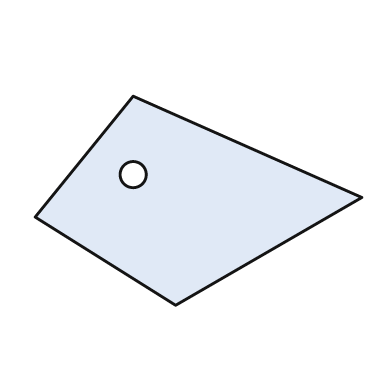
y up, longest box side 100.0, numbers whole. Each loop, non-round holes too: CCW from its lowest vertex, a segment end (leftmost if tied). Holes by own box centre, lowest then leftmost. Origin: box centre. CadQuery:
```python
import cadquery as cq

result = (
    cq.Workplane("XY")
    .moveTo(-7.0, -32.0)
    .lineTo(50.0, 1.0)
    .lineTo(-20.0, 32.0)
    .lineTo(-50.0, -5.0)
    .close()
    .moveTo(-20.0, 8.0)
    .circle(4.0)
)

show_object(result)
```